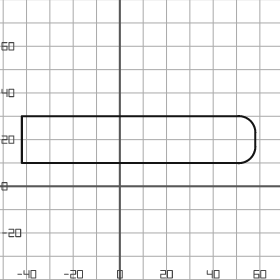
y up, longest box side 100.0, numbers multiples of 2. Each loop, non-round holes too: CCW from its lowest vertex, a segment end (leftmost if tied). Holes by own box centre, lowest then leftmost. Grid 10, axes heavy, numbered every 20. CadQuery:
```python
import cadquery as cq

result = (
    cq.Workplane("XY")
    .moveTo(-42.0, 10.0)
    .lineTo(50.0, 10.0)
    .threePointArc((56.0, 12.0), (58.0, 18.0))
    .lineTo(58.0, 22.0)
    .threePointArc((56.0, 28.0), (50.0, 30.0))
    .lineTo(-42.0, 30.0)
    .close()
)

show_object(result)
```